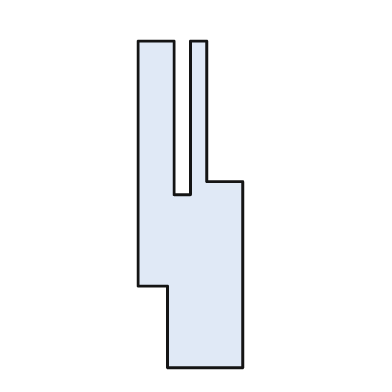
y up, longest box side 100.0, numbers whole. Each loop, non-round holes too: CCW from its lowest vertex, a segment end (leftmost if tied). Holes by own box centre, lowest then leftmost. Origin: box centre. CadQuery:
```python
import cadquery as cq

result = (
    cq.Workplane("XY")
    .moveTo(-7.0, -50.0)
    .lineTo(16.0, -50.0)
    .lineTo(16.0, 7.0)
    .lineTo(5.0, 7.0)
    .lineTo(5.0, 50.0)
    .lineTo(0.0, 50.0)
    .lineTo(0.0, 3.0)
    .lineTo(-5.0, 3.0)
    .lineTo(-5.0, 50.0)
    .lineTo(-16.0, 50.0)
    .lineTo(-16.0, -25.0)
    .lineTo(-7.0, -25.0)
    .close()
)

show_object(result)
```